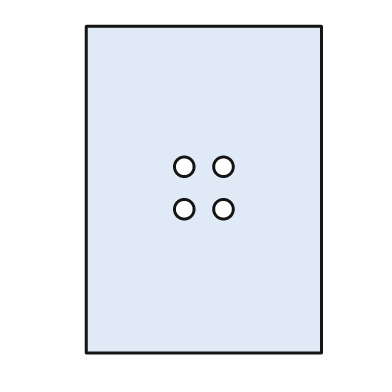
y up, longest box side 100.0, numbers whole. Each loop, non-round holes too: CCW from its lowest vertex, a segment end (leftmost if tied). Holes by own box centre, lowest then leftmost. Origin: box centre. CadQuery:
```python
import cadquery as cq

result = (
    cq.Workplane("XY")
    .moveTo(-36.0, -50.0)
    .lineTo(36.0, -50.0)
    .lineTo(36.0, 50.0)
    .lineTo(-36.0, 50.0)
    .close()
    .moveTo(-6.0, -6.0)
    .circle(3.0)
    .moveTo(6.0, -6.0)
    .circle(3.0)
    .moveTo(-6.0, 7.0)
    .circle(3.0)
    .moveTo(6.0, 7.0)
    .circle(3.0)
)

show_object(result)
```